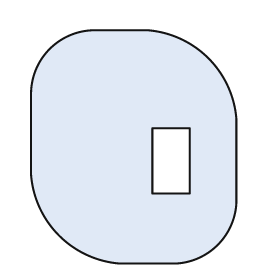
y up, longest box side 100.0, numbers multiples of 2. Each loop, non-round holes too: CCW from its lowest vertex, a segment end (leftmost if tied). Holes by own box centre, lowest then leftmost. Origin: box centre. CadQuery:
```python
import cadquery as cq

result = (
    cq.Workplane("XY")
    .moveTo(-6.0, -50.0)
    .lineTo(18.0, -50.0)
    .threePointArc((36.0, -42.0), (44.0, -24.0))
    .lineTo(44.0, 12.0)
    .threePointArc((32.0, 38.0), (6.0, 50.0))
    .lineTo(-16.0, 50.0)
    .threePointArc((-36.0, 42.0), (-44.0, 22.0))
    .lineTo(-44.0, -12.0)
    .threePointArc((-32.0, -38.0), (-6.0, -50.0))
    .close()
    .moveTo(8.0, -20.0)
    .lineTo(24.0, -20.0)
    .lineTo(24.0, 8.0)
    .lineTo(8.0, 8.0)
    .close()
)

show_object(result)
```